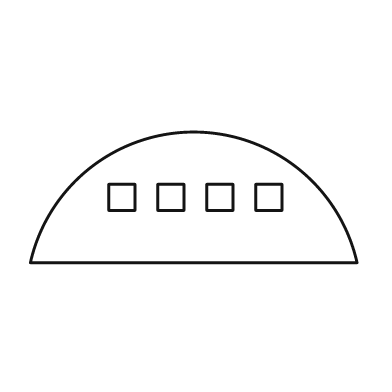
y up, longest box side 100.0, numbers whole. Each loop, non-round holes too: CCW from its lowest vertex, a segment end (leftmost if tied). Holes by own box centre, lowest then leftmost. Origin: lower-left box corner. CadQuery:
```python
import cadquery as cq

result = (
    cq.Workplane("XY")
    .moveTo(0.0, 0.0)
    .lineTo(100.0, 0.0)
    .threePointArc((50.0, 40.0), (0.0, 0.0))
    .close()
    .moveTo(24.0, 16.0)
    .lineTo(32.0, 16.0)
    .lineTo(32.0, 24.0)
    .lineTo(24.0, 24.0)
    .close()
    .moveTo(39.0, 16.0)
    .lineTo(47.0, 16.0)
    .lineTo(47.0, 24.0)
    .lineTo(39.0, 24.0)
    .close()
    .moveTo(54.0, 16.0)
    .lineTo(62.0, 16.0)
    .lineTo(62.0, 24.0)
    .lineTo(54.0, 24.0)
    .close()
    .moveTo(69.0, 16.0)
    .lineTo(77.0, 16.0)
    .lineTo(77.0, 24.0)
    .lineTo(69.0, 24.0)
    .close()
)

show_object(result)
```